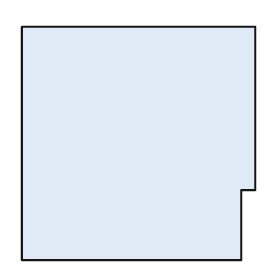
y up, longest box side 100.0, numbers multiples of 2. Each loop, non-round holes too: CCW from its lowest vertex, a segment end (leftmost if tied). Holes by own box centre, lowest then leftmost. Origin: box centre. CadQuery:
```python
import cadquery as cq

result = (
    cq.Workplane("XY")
    .moveTo(-50.0, -50.0)
    .lineTo(44.0, -50.0)
    .lineTo(44.0, -20.0)
    .lineTo(50.0, -20.0)
    .lineTo(50.0, 50.0)
    .lineTo(-50.0, 50.0)
    .close()
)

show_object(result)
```